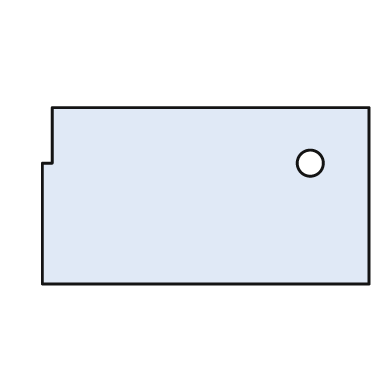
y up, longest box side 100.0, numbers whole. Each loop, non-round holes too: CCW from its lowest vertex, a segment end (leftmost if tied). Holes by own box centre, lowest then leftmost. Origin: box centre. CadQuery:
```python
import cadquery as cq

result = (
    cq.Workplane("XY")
    .moveTo(-50.0, -27.0)
    .lineTo(50.0, -27.0)
    .lineTo(50.0, 27.0)
    .lineTo(-47.0, 27.0)
    .lineTo(-47.0, 10.0)
    .lineTo(-50.0, 10.0)
    .close()
    .moveTo(32.0, 10.0)
    .circle(4.0)
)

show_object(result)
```